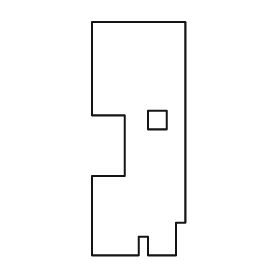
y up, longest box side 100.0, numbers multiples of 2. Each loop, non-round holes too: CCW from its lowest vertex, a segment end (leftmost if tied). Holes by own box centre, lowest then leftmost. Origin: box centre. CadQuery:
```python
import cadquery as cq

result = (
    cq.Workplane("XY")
    .moveTo(-20.0, -50.0)
    .lineTo(0.0, -50.0)
    .lineTo(0.0, -42.0)
    .lineTo(4.0, -42.0)
    .lineTo(4.0, -50.0)
    .lineTo(16.0, -50.0)
    .lineTo(16.0, -36.0)
    .lineTo(20.0, -36.0)
    .lineTo(20.0, 50.0)
    .lineTo(-20.0, 50.0)
    .lineTo(-20.0, 10.0)
    .lineTo(-6.0, 10.0)
    .lineTo(-6.0, -16.0)
    .lineTo(-20.0, -16.0)
    .close()
    .moveTo(4.0, 4.0)
    .lineTo(12.0, 4.0)
    .lineTo(12.0, 12.0)
    .lineTo(4.0, 12.0)
    .close()
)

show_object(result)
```